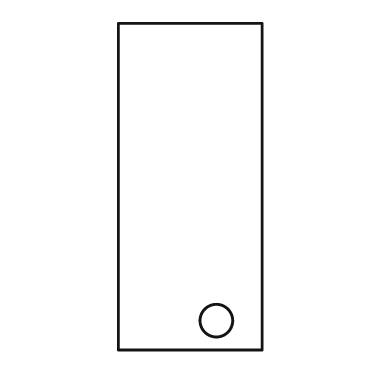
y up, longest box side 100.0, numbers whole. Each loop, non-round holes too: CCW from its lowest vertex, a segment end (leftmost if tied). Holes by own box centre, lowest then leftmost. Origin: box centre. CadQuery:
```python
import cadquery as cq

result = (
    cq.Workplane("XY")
    .moveTo(-22.0, -50.0)
    .lineTo(22.0, -50.0)
    .lineTo(22.0, 50.0)
    .lineTo(-22.0, 50.0)
    .close()
    .moveTo(8.0, -41.0)
    .circle(5.0)
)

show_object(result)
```